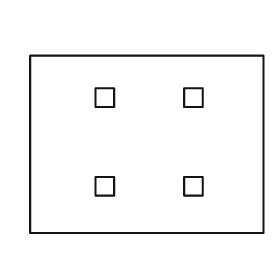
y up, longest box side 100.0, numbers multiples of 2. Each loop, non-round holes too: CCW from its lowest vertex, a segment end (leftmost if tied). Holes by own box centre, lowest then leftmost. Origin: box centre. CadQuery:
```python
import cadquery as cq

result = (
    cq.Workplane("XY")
    .moveTo(-50.0, -38.0)
    .lineTo(50.0, -38.0)
    .lineTo(50.0, 38.0)
    .lineTo(-50.0, 38.0)
    .close()
    .moveTo(-22.0, -22.0)
    .lineTo(-14.0, -22.0)
    .lineTo(-14.0, -14.0)
    .lineTo(-22.0, -14.0)
    .close()
    .moveTo(16.0, -22.0)
    .lineTo(24.0, -22.0)
    .lineTo(24.0, -14.0)
    .lineTo(16.0, -14.0)
    .close()
    .moveTo(-22.0, 16.0)
    .lineTo(-14.0, 16.0)
    .lineTo(-14.0, 24.0)
    .lineTo(-22.0, 24.0)
    .close()
    .moveTo(16.0, 16.0)
    .lineTo(24.0, 16.0)
    .lineTo(24.0, 24.0)
    .lineTo(16.0, 24.0)
    .close()
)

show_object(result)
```